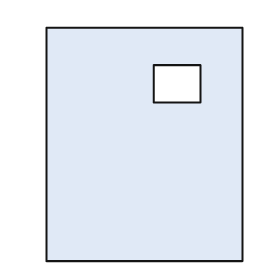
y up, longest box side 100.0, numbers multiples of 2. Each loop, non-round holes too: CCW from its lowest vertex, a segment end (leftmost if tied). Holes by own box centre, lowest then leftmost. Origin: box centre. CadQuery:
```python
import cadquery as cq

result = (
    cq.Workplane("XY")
    .moveTo(-42.0, -50.0)
    .lineTo(42.0, -50.0)
    .lineTo(42.0, 50.0)
    .lineTo(-42.0, 50.0)
    .close()
    .moveTo(4.0, 18.0)
    .lineTo(24.0, 18.0)
    .lineTo(24.0, 34.0)
    .lineTo(4.0, 34.0)
    .close()
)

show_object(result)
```